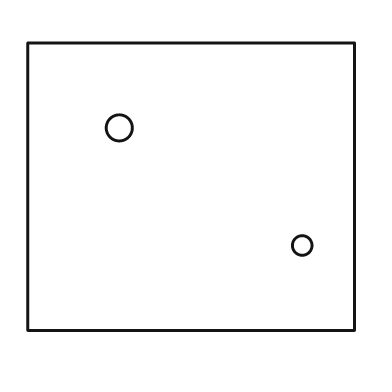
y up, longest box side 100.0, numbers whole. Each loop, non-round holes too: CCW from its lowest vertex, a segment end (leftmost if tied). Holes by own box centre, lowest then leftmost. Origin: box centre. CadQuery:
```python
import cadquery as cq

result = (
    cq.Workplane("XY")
    .moveTo(-50.0, -44.0)
    .lineTo(50.0, -44.0)
    .lineTo(50.0, 44.0)
    .lineTo(-50.0, 44.0)
    .close()
    .moveTo(34.0, -18.0)
    .circle(3.0)
    .moveTo(-22.0, 18.0)
    .circle(4.0)
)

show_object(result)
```